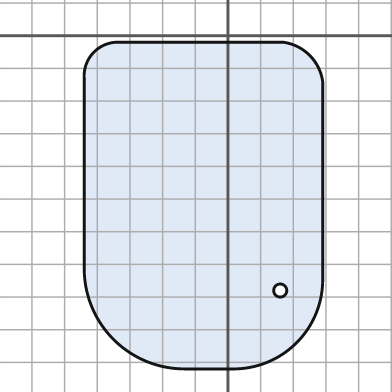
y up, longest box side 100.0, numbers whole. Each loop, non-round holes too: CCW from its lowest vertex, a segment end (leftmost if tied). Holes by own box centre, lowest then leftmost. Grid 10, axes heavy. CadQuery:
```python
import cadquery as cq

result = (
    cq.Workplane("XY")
    .moveTo(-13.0, -102.0)
    .lineTo(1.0, -102.0)
    .threePointArc((21.0, -94.0), (29.0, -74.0))
    .lineTo(29.0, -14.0)
    .threePointArc((25.0, -6.0), (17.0, -2.0))
    .lineTo(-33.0, -2.0)
    .threePointArc((-41.0, -5.0), (-44.0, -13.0))
    .lineTo(-44.0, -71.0)
    .threePointArc((-35.0, -93.0), (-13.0, -102.0))
    .close()
    .moveTo(16.0, -78.0)
    .circle(2.0)
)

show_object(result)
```